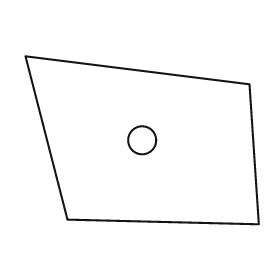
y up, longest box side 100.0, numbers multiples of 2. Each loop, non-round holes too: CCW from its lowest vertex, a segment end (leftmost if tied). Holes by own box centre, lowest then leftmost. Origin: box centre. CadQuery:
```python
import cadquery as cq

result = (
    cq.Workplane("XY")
    .moveTo(50.0, -36.0)
    .lineTo(46.0, 24.0)
    .lineTo(-50.0, 36.0)
    .lineTo(-32.0, -34.0)
    .close()
    .moveTo(0.0, 0.0)
    .circle(6.0)
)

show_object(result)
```